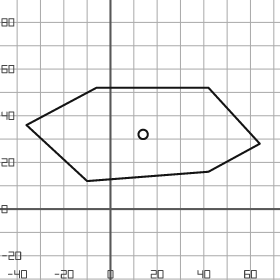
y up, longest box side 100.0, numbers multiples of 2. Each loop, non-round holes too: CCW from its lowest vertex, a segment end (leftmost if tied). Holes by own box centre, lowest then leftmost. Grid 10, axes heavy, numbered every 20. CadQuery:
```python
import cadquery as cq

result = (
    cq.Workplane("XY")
    .moveTo(-10.0, 12.0)
    .lineTo(42.0, 16.0)
    .lineTo(64.0, 28.0)
    .lineTo(42.0, 52.0)
    .lineTo(-6.0, 52.0)
    .lineTo(-36.0, 36.0)
    .close()
    .moveTo(14.0, 32.0)
    .circle(2.0)
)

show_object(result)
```